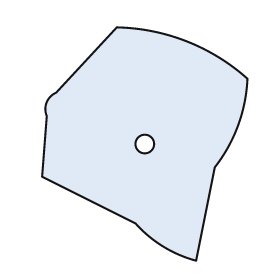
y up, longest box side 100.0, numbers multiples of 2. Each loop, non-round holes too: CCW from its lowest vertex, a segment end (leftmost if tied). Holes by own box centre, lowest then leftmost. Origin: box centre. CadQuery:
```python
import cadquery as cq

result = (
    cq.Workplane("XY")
    .moveTo(22.0, -50.0)
    .lineTo(30.0, -10.0)
    .threePointArc((40.0, 8.0), (44.0, 28.0))
    .threePointArc((18.0, 44.0), (-12.0, 50.0))
    .lineTo(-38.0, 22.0)
    .threePointArc((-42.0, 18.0), (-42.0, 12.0))
    .lineTo(-44.0, -14.0)
    .lineTo(-4.0, -34.0)
    .threePointArc((8.0, -44.0), (22.0, -50.0))
    .close()
    .moveTo(0.0, 0.0)
    .circle(4.0)
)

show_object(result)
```